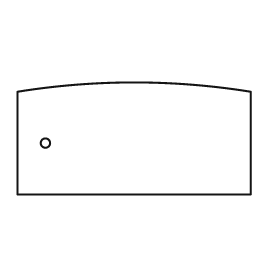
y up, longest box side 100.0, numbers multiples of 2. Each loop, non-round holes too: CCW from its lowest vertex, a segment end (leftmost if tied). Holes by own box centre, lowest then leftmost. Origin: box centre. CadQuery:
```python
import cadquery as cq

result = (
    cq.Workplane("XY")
    .moveTo(-50.0, -24.0)
    .lineTo(50.0, -24.0)
    .lineTo(50.0, 20.0)
    .threePointArc((0.0, 24.0), (-50.0, 20.0))
    .close()
    .moveTo(-38.0, -2.0)
    .circle(2.0)
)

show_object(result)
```